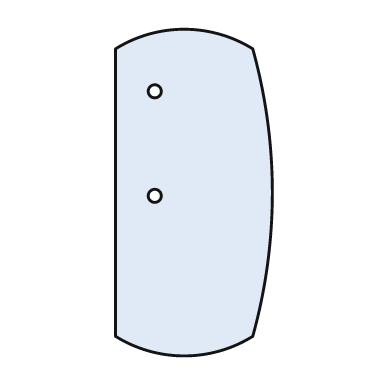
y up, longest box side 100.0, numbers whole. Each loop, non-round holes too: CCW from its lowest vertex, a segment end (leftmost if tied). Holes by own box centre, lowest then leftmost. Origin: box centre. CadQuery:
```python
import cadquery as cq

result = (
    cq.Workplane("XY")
    .moveTo(-24.0, -44.0)
    .threePointArc((-3.0, -50.0), (18.0, -44.0))
    .threePointArc((24.0, 0.0), (18.0, 44.0))
    .threePointArc((-3.0, 50.0), (-24.0, 44.0))
    .close()
    .moveTo(-12.0, -1.0)
    .circle(2.0)
    .moveTo(-12.0, 31.0)
    .circle(2.0)
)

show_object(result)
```